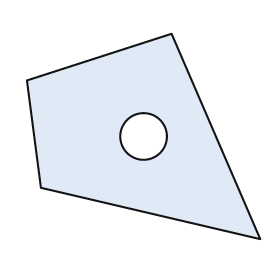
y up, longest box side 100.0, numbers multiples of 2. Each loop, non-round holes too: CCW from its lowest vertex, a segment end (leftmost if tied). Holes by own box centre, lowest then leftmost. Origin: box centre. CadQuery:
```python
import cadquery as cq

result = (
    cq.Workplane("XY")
    .moveTo(50.0, -44.0)
    .lineTo(12.0, 44.0)
    .lineTo(-50.0, 24.0)
    .lineTo(-44.0, -22.0)
    .close()
    .moveTo(0.0, 0.0)
    .circle(10.0)
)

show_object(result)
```